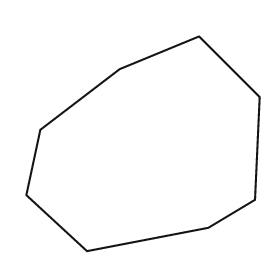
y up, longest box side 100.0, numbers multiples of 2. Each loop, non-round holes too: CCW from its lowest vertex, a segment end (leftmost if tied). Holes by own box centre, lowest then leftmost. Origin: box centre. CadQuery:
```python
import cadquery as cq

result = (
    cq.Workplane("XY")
    .moveTo(-24.0, -46.0)
    .lineTo(28.0, -36.0)
    .lineTo(48.0, -24.0)
    .lineTo(50.0, 20.0)
    .lineTo(24.0, 46.0)
    .lineTo(-10.0, 32.0)
    .lineTo(-44.0, 6.0)
    .lineTo(-50.0, -22.0)
    .close()
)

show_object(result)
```